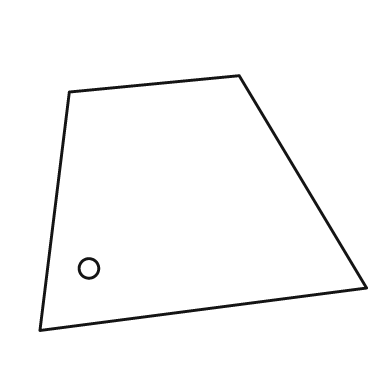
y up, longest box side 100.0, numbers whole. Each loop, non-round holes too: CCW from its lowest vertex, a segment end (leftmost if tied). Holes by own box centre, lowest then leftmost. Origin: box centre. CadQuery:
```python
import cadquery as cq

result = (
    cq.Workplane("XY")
    .moveTo(-50.0, -39.0)
    .lineTo(50.0, -26.0)
    .lineTo(11.0, 39.0)
    .lineTo(-41.0, 34.0)
    .close()
    .moveTo(-35.0, -20.0)
    .circle(3.0)
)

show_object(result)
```